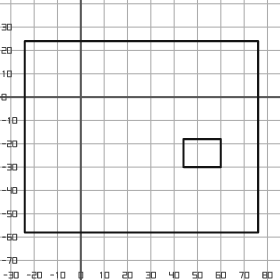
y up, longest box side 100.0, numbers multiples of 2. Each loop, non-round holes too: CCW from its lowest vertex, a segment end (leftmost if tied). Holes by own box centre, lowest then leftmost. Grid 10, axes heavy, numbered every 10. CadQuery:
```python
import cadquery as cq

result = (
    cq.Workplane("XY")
    .moveTo(-24.0, -58.0)
    .lineTo(76.0, -58.0)
    .lineTo(76.0, 24.0)
    .lineTo(-24.0, 24.0)
    .close()
    .moveTo(44.0, -30.0)
    .lineTo(60.0, -30.0)
    .lineTo(60.0, -18.0)
    .lineTo(44.0, -18.0)
    .close()
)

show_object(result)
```